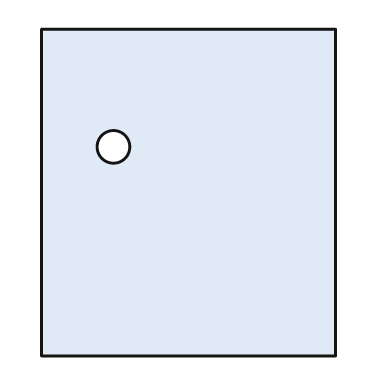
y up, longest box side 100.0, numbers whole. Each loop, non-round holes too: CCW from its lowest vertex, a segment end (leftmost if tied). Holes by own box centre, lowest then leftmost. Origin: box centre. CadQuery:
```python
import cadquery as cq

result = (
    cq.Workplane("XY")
    .moveTo(-45.0, -50.0)
    .lineTo(45.0, -50.0)
    .lineTo(45.0, 50.0)
    .lineTo(-45.0, 50.0)
    .close()
    .moveTo(-23.0, 14.0)
    .circle(5.0)
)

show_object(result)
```